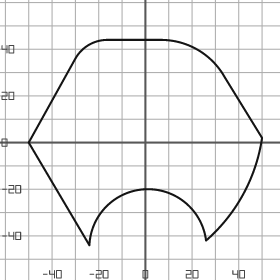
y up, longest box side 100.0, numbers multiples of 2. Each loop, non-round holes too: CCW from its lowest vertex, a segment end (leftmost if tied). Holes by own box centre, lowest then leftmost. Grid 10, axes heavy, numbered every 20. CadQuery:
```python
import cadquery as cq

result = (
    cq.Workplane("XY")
    .moveTo(-24.0, -44.0)
    .threePointArc((0.0, -20.0), (26.0, -42.0))
    .threePointArc((42.0, -22.0), (50.0, 2.0))
    .lineTo(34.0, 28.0)
    .threePointArc((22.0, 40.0), (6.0, 44.0))
    .lineTo(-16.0, 44.0)
    .threePointArc((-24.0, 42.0), (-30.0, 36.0))
    .lineTo(-50.0, 0.0)
    .close()
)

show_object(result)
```